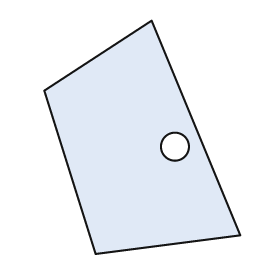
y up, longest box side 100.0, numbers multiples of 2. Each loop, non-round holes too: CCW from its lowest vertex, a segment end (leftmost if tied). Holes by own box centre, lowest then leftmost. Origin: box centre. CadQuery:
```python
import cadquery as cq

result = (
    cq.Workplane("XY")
    .moveTo(-20.0, -50.0)
    .lineTo(42.0, -42.0)
    .lineTo(4.0, 50.0)
    .lineTo(-42.0, 20.0)
    .close()
    .moveTo(14.0, -4.0)
    .circle(6.0)
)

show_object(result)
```